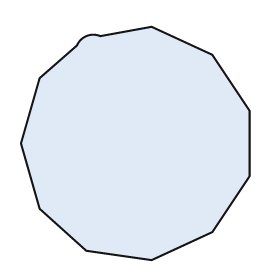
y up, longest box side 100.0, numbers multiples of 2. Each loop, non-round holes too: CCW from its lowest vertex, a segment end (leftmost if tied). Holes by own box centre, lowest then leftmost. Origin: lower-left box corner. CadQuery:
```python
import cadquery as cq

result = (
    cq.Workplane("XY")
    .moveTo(56.0, 0.0)
    .lineTo(82.0, 12.0)
    .lineTo(98.0, 36.0)
    .lineTo(98.0, 64.0)
    .lineTo(82.0, 88.0)
    .lineTo(56.0, 100.0)
    .lineTo(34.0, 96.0)
    .threePointArc((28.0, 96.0), (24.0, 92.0))
    .lineTo(8.0, 78.0)
    .lineTo(0.0, 50.0)
    .lineTo(8.0, 22.0)
    .lineTo(28.0, 4.0)
    .close()
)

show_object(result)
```